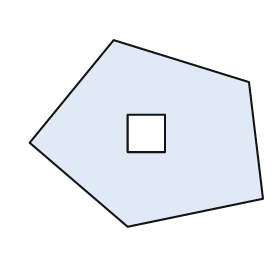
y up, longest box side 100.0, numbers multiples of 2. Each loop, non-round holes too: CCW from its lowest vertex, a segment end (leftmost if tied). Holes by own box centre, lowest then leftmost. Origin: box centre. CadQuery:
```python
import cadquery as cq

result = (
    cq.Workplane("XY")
    .moveTo(-8.0, -40.0)
    .lineTo(50.0, -28.0)
    .lineTo(44.0, 22.0)
    .lineTo(-14.0, 40.0)
    .lineTo(-50.0, -4.0)
    .close()
    .moveTo(-8.0, -8.0)
    .lineTo(8.0, -8.0)
    .lineTo(8.0, 8.0)
    .lineTo(-8.0, 8.0)
    .close()
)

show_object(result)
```